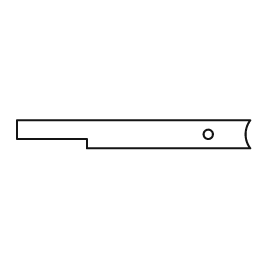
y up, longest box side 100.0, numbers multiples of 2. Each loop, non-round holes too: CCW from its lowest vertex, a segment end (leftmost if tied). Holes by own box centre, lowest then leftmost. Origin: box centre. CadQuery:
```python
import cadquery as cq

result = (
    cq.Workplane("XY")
    .moveTo(-20.0, -6.0)
    .lineTo(50.0, -6.0)
    .threePointArc((48.0, 0.0), (50.0, 6.0))
    .lineTo(-50.0, 6.0)
    .lineTo(-50.0, -2.0)
    .lineTo(-20.0, -2.0)
    .close()
    .moveTo(32.0, 0.0)
    .circle(2.0)
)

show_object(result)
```